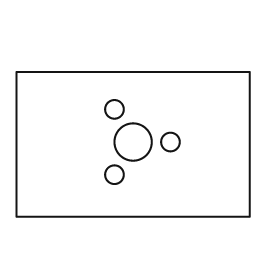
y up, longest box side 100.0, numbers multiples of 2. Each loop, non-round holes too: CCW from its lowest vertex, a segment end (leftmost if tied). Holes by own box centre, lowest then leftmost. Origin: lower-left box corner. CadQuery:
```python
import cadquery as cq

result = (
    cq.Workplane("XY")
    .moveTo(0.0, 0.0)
    .lineTo(100.0, 0.0)
    .lineTo(100.0, 62.0)
    .lineTo(0.0, 62.0)
    .close()
    .moveTo(42.0, 18.0)
    .circle(4.0)
    .moveTo(50.0, 32.0)
    .circle(8.0)
    .moveTo(66.0, 32.0)
    .circle(4.0)
    .moveTo(42.0, 46.0)
    .circle(4.0)
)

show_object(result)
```